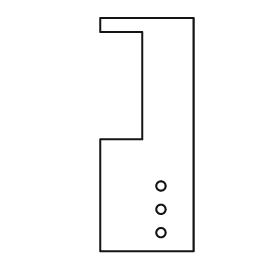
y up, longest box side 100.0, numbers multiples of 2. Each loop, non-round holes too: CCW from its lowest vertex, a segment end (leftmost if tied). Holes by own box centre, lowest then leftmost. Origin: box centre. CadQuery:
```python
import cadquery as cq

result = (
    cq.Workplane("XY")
    .moveTo(-20.0, -50.0)
    .lineTo(20.0, -50.0)
    .lineTo(20.0, 50.0)
    .lineTo(-20.0, 50.0)
    .lineTo(-20.0, 44.0)
    .lineTo(-2.0, 44.0)
    .lineTo(-2.0, -2.0)
    .lineTo(-20.0, -2.0)
    .close()
    .moveTo(6.0, -42.0)
    .circle(2.0)
    .moveTo(6.0, -32.0)
    .circle(2.0)
    .moveTo(6.0, -22.0)
    .circle(2.0)
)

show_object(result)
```